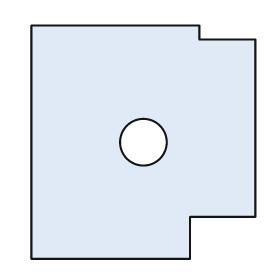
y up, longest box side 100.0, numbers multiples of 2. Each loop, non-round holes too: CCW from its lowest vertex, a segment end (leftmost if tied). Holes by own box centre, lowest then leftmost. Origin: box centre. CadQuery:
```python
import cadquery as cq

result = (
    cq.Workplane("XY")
    .moveTo(-48.0, -50.0)
    .lineTo(20.0, -50.0)
    .lineTo(20.0, -32.0)
    .lineTo(48.0, -32.0)
    .lineTo(48.0, 44.0)
    .lineTo(24.0, 44.0)
    .lineTo(24.0, 50.0)
    .lineTo(-48.0, 50.0)
    .close()
    .moveTo(0.0, 0.0)
    .circle(10.0)
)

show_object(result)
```